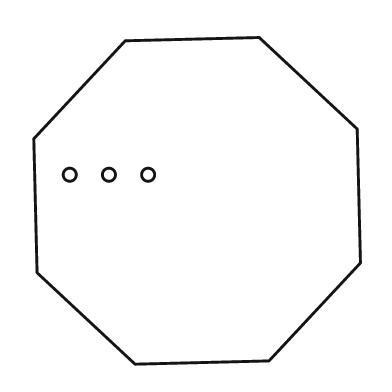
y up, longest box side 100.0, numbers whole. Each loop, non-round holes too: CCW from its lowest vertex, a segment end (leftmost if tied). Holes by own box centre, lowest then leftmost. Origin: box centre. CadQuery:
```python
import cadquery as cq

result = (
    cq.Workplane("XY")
    .moveTo(-19.0, -50.0)
    .lineTo(22.0, -49.0)
    .lineTo(50.0, -19.0)
    .lineTo(49.0, 22.0)
    .lineTo(19.0, 50.0)
    .lineTo(-22.0, 49.0)
    .lineTo(-50.0, 19.0)
    .lineTo(-49.0, -22.0)
    .close()
    .moveTo(-39.0, 8.0)
    .circle(2.0)
    .moveTo(-27.0, 8.0)
    .circle(2.0)
    .moveTo(-15.0, 8.0)
    .circle(2.0)
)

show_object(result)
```